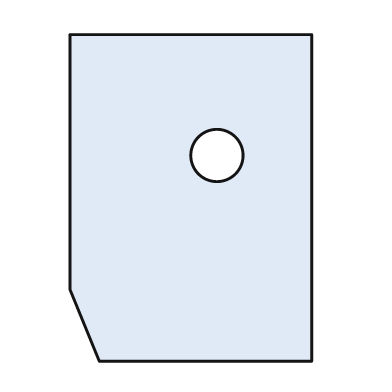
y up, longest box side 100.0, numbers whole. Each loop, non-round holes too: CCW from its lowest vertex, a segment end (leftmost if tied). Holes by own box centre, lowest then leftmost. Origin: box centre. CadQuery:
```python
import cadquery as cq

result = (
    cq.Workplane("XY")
    .moveTo(-28.0, -50.0)
    .lineTo(37.0, -50.0)
    .lineTo(37.0, 50.0)
    .lineTo(-37.0, 50.0)
    .lineTo(-37.0, -28.0)
    .close()
    .moveTo(8.0, 13.0)
    .circle(8.0)
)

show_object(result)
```